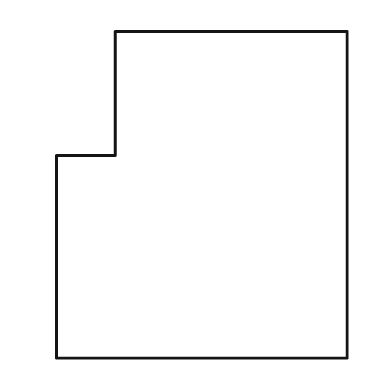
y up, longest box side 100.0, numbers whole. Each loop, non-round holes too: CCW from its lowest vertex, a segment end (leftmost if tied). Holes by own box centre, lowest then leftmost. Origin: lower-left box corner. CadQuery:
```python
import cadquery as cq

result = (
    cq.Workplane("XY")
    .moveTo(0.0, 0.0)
    .lineTo(89.0, 0.0)
    .lineTo(89.0, 100.0)
    .lineTo(18.0, 100.0)
    .lineTo(18.0, 62.0)
    .lineTo(0.0, 62.0)
    .close()
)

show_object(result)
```